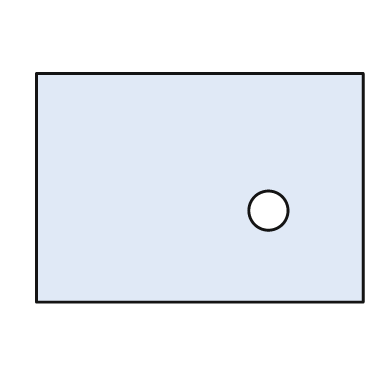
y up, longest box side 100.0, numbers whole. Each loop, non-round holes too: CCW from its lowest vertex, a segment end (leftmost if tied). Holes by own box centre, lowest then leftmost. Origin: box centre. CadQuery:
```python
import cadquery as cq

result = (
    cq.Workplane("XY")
    .moveTo(-50.0, -35.0)
    .lineTo(50.0, -35.0)
    .lineTo(50.0, 35.0)
    .lineTo(-50.0, 35.0)
    .close()
    .moveTo(21.0, -7.0)
    .circle(6.0)
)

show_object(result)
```